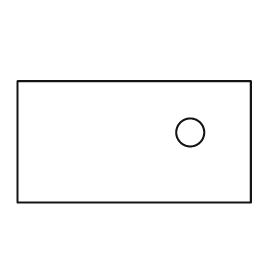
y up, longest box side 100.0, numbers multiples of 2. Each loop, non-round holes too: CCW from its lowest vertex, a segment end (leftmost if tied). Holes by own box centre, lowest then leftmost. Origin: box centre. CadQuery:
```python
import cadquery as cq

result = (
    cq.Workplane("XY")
    .moveTo(-50.0, -26.0)
    .lineTo(50.0, -26.0)
    .lineTo(50.0, 26.0)
    .lineTo(-50.0, 26.0)
    .close()
    .moveTo(24.0, 4.0)
    .circle(6.0)
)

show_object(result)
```